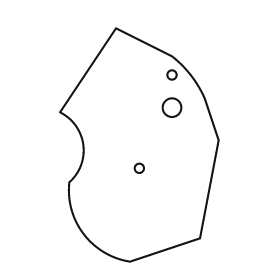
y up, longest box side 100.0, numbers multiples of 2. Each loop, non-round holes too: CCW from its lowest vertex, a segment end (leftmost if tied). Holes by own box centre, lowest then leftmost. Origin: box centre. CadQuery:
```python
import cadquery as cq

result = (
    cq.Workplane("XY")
    .moveTo(-4.0, -50.0)
    .lineTo(26.0, -40.0)
    .lineTo(34.0, 2.0)
    .lineTo(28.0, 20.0)
    .threePointArc((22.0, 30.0), (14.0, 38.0))
    .lineTo(-10.0, 50.0)
    .lineTo(-34.0, 14.0)
    .threePointArc((-24.0, 0.0), (-30.0, -16.0))
    .threePointArc((-24.0, -38.0), (-4.0, -50.0))
    .close()
    .moveTo(0.0, -10.0)
    .circle(2.0)
    .moveTo(14.0, 16.0)
    .circle(4.0)
    .moveTo(14.0, 30.0)
    .circle(2.0)
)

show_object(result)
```